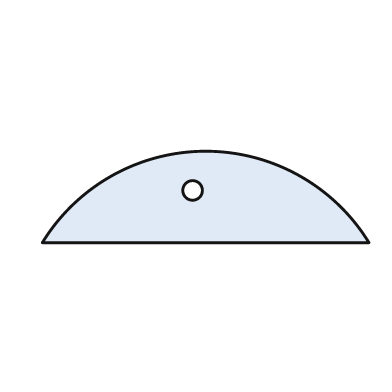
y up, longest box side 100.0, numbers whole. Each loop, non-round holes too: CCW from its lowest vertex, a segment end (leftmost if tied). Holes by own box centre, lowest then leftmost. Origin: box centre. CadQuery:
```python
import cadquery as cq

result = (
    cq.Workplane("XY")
    .moveTo(-50.0, -14.0)
    .lineTo(50.0, -14.0)
    .threePointArc((0.0, 14.0), (-50.0, -14.0))
    .close()
    .moveTo(-4.0, 2.0)
    .circle(3.0)
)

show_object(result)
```